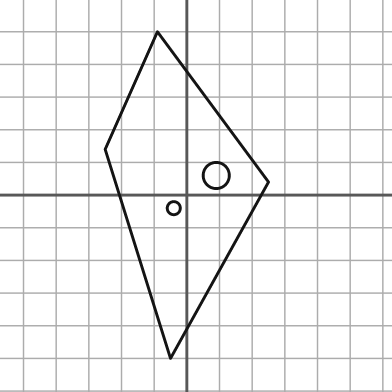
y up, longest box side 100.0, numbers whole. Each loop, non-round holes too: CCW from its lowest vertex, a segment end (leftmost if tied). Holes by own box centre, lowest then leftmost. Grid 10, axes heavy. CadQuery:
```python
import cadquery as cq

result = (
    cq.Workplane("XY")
    .moveTo(-5.0, -50.0)
    .lineTo(25.0, 4.0)
    .lineTo(-9.0, 50.0)
    .lineTo(-25.0, 14.0)
    .close()
    .moveTo(-4.0, -4.0)
    .circle(2.0)
    .moveTo(9.0, 6.0)
    .circle(4.0)
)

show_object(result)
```